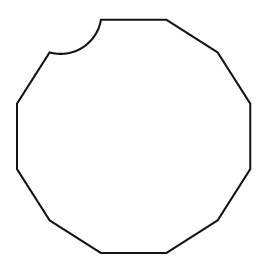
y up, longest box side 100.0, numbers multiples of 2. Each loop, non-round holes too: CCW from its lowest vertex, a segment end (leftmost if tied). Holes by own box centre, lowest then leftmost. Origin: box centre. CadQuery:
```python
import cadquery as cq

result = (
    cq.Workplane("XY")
    .moveTo(-14.0, -50.0)
    .lineTo(14.0, -50.0)
    .lineTo(36.0, -36.0)
    .lineTo(50.0, -14.0)
    .lineTo(50.0, 14.0)
    .lineTo(36.0, 36.0)
    .lineTo(14.0, 50.0)
    .lineTo(-14.0, 50.0)
    .threePointArc((-22.0, 38.0), (-36.0, 36.0))
    .lineTo(-50.0, 14.0)
    .lineTo(-50.0, -14.0)
    .lineTo(-36.0, -36.0)
    .close()
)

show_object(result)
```